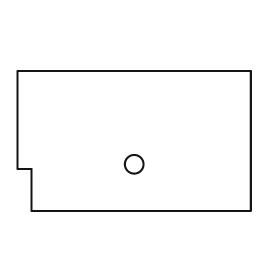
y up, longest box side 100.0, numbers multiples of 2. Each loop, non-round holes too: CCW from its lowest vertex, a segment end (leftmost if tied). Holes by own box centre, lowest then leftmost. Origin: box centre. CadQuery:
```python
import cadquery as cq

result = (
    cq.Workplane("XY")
    .moveTo(-44.0, -30.0)
    .lineTo(50.0, -30.0)
    .lineTo(50.0, 30.0)
    .lineTo(-50.0, 30.0)
    .lineTo(-50.0, -12.0)
    .lineTo(-44.0, -12.0)
    .close()
    .moveTo(0.0, -10.0)
    .circle(4.0)
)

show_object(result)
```